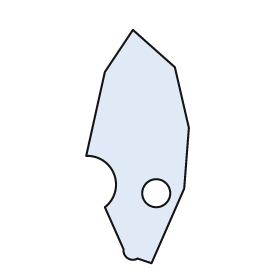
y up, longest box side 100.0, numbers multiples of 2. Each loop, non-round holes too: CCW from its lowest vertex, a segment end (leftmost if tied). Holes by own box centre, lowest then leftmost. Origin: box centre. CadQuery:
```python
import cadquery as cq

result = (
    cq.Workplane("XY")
    .moveTo(6.0, -50.0)
    .lineTo(20.0, -18.0)
    .lineTo(22.0, 8.0)
    .lineTo(16.0, 34.0)
    .lineTo(-2.0, 50.0)
    .lineTo(-14.0, 32.0)
    .lineTo(-22.0, -4.0)
    .threePointArc((-10.0, -12.0), (-14.0, -26.0))
    .lineTo(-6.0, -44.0)
    .threePointArc((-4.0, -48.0), (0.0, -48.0))
    .close()
    .moveTo(8.0, -20.0)
    .circle(6.0)
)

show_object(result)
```